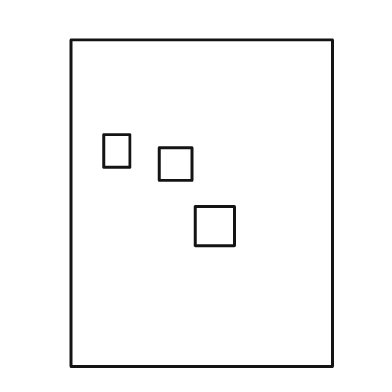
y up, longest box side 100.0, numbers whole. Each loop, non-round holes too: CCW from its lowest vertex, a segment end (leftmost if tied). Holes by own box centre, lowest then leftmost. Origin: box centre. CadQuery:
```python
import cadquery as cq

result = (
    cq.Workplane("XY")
    .moveTo(-40.0, -50.0)
    .lineTo(40.0, -50.0)
    .lineTo(40.0, 50.0)
    .lineTo(-40.0, 50.0)
    .close()
    .moveTo(-2.0, -13.0)
    .lineTo(10.0, -13.0)
    .lineTo(10.0, -1.0)
    .lineTo(-2.0, -1.0)
    .close()
    .moveTo(-13.0, 7.0)
    .lineTo(-3.0, 7.0)
    .lineTo(-3.0, 17.0)
    .lineTo(-13.0, 17.0)
    .close()
    .moveTo(-30.0, 11.0)
    .lineTo(-22.0, 11.0)
    .lineTo(-22.0, 21.0)
    .lineTo(-30.0, 21.0)
    .close()
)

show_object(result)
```